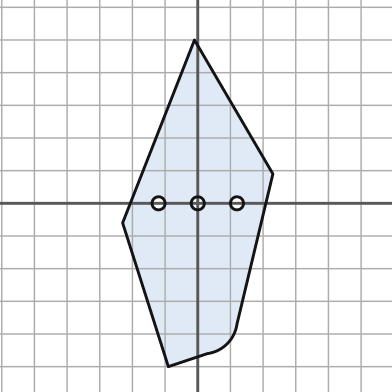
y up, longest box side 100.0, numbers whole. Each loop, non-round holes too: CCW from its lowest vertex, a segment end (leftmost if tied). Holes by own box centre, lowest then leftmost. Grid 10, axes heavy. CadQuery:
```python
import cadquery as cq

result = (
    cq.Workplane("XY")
    .moveTo(-9.0, -50.0)
    .lineTo(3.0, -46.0)
    .threePointArc((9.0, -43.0), (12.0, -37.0))
    .lineTo(23.0, 9.0)
    .lineTo(-1.0, 50.0)
    .lineTo(-23.0, -6.0)
    .close()
    .moveTo(-12.0, 0.0)
    .circle(2.0)
    .moveTo(0.0, 0.0)
    .circle(2.0)
    .moveTo(12.0, 0.0)
    .circle(2.0)
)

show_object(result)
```